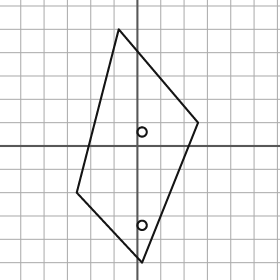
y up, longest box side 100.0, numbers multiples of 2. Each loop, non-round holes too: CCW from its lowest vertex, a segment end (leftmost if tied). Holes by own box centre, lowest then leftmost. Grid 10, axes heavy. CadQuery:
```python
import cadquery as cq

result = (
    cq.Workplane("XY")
    .moveTo(2.0, -50.0)
    .lineTo(26.0, 10.0)
    .lineTo(-8.0, 50.0)
    .lineTo(-26.0, -20.0)
    .close()
    .moveTo(2.0, -34.0)
    .circle(2.0)
    .moveTo(2.0, 6.0)
    .circle(2.0)
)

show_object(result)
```